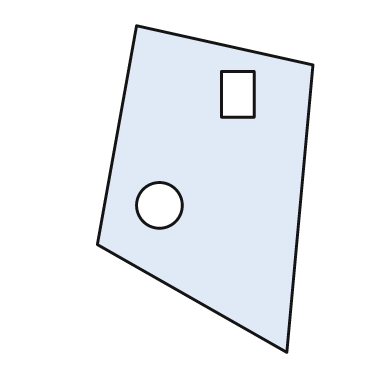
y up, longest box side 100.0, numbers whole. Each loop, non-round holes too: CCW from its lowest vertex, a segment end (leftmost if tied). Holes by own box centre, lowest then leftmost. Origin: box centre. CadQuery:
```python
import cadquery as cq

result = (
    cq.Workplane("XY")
    .moveTo(25.0, -50.0)
    .lineTo(33.0, 38.0)
    .lineTo(-21.0, 50.0)
    .lineTo(-33.0, -17.0)
    .close()
    .moveTo(-14.0, -5.0)
    .circle(7.0)
    .moveTo(5.0, 22.0)
    .lineTo(15.0, 22.0)
    .lineTo(15.0, 36.0)
    .lineTo(5.0, 36.0)
    .close()
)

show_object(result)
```